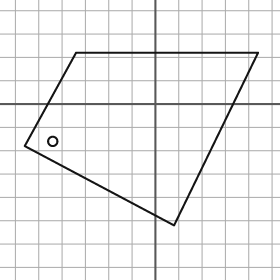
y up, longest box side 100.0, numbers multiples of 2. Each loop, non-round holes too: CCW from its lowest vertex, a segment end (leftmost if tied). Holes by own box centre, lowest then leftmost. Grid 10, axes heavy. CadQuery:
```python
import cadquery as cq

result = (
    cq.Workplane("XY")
    .moveTo(8.0, -52.0)
    .lineTo(44.0, 22.0)
    .lineTo(-34.0, 22.0)
    .lineTo(-56.0, -18.0)
    .close()
    .moveTo(-44.0, -16.0)
    .circle(2.0)
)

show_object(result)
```